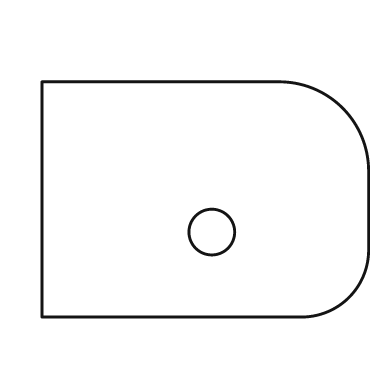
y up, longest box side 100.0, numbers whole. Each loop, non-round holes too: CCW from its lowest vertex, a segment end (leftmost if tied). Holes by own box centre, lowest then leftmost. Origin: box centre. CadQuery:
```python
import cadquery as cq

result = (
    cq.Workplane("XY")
    .moveTo(-50.0, -36.0)
    .lineTo(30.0, -36.0)
    .threePointArc((44.0, -30.0), (50.0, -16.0))
    .lineTo(50.0, 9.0)
    .threePointArc((42.0, 28.0), (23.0, 36.0))
    .lineTo(-50.0, 36.0)
    .close()
    .moveTo(2.0, -10.0)
    .circle(7.0)
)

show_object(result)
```